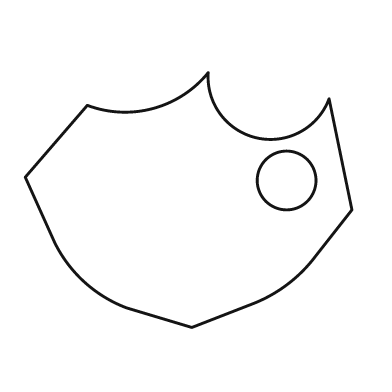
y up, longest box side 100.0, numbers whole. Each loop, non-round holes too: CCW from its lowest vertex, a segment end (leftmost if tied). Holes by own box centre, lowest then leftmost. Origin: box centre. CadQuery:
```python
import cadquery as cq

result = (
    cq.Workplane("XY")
    .moveTo(1.0, -39.0)
    .lineTo(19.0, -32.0)
    .threePointArc((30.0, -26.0), (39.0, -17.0))
    .lineTo(50.0, -3.0)
    .lineTo(43.0, 31.0)
    .threePointArc((21.0, 19.0), (6.0, 39.0))
    .threePointArc((-11.0, 28.0), (-31.0, 29.0))
    .lineTo(-50.0, 7.0)
    .lineTo(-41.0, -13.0)
    .threePointArc((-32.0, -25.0), (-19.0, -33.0))
    .close()
    .moveTo(30.0, 6.0)
    .circle(9.0)
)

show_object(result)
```